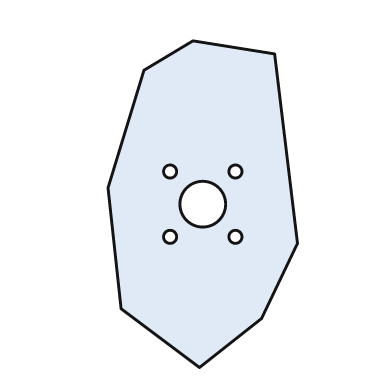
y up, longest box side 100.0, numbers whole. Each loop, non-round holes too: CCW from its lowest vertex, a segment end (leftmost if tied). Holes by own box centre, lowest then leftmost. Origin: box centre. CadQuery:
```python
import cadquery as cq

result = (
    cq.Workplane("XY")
    .moveTo(-1.0, -50.0)
    .lineTo(18.0, -35.0)
    .lineTo(29.0, -12.0)
    .lineTo(22.0, 46.0)
    .lineTo(-3.0, 50.0)
    .lineTo(-18.0, 41.0)
    .lineTo(-29.0, 5.0)
    .lineTo(-25.0, -32.0)
    .close()
    .moveTo(-10.0, -10.0)
    .circle(2.0)
    .moveTo(10.0, -10.0)
    .circle(2.0)
    .moveTo(0.0, 0.0)
    .circle(7.0)
    .moveTo(-10.0, 10.0)
    .circle(2.0)
    .moveTo(10.0, 10.0)
    .circle(2.0)
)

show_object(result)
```